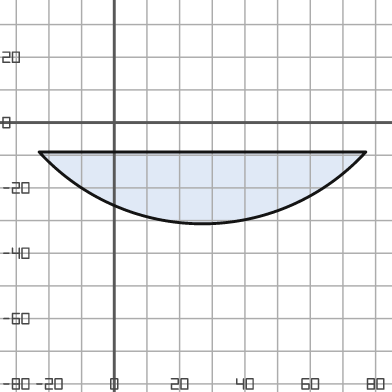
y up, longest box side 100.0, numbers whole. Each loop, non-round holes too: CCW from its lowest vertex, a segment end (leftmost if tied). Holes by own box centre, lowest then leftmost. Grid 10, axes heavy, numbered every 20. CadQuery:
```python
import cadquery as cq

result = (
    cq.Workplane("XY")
    .moveTo(-23.0, -9.0)
    .threePointArc((27.0, -31.0), (77.0, -9.0))
    .close()
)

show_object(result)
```